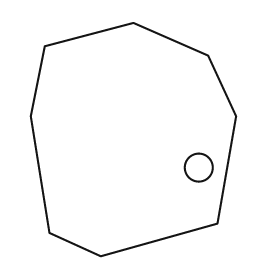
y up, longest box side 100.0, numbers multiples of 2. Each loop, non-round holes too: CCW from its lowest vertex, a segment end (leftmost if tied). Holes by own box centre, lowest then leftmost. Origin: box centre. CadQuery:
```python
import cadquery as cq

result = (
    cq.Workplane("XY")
    .moveTo(-14.0, -50.0)
    .lineTo(36.0, -36.0)
    .lineTo(44.0, 10.0)
    .lineTo(32.0, 36.0)
    .lineTo(0.0, 50.0)
    .lineTo(-38.0, 40.0)
    .lineTo(-44.0, 10.0)
    .lineTo(-36.0, -40.0)
    .close()
    .moveTo(28.0, -12.0)
    .circle(6.0)
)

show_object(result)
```